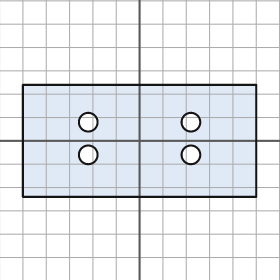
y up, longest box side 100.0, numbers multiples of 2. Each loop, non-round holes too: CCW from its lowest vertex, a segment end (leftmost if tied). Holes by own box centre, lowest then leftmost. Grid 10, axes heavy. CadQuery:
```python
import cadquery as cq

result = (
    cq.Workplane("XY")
    .moveTo(-50.0, -24.0)
    .lineTo(50.0, -24.0)
    .lineTo(50.0, 24.0)
    .lineTo(-50.0, 24.0)
    .close()
    .moveTo(-22.0, -6.0)
    .circle(4.0)
    .moveTo(22.0, -6.0)
    .circle(4.0)
    .moveTo(-22.0, 8.0)
    .circle(4.0)
    .moveTo(22.0, 8.0)
    .circle(4.0)
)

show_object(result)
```